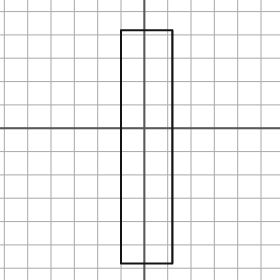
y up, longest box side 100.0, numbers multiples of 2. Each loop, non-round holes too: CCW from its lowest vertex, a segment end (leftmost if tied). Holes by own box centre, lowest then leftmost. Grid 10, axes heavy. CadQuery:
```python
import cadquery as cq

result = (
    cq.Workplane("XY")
    .moveTo(-10.0, -58.0)
    .lineTo(12.0, -58.0)
    .lineTo(12.0, 42.0)
    .lineTo(-10.0, 42.0)
    .close()
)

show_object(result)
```